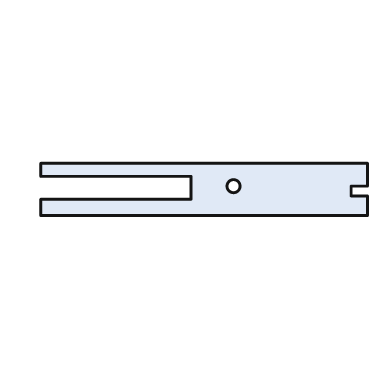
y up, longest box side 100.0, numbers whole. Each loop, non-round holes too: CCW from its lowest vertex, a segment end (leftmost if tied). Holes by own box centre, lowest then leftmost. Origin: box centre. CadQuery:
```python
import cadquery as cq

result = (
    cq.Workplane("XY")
    .moveTo(-50.0, -8.0)
    .lineTo(50.0, -8.0)
    .lineTo(50.0, -2.0)
    .lineTo(45.0, -2.0)
    .lineTo(45.0, 1.0)
    .lineTo(50.0, 1.0)
    .lineTo(50.0, 8.0)
    .lineTo(-50.0, 8.0)
    .lineTo(-50.0, 4.0)
    .lineTo(-4.0, 4.0)
    .lineTo(-4.0, -3.0)
    .lineTo(-50.0, -3.0)
    .close()
    .moveTo(9.0, 1.0)
    .circle(2.0)
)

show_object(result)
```